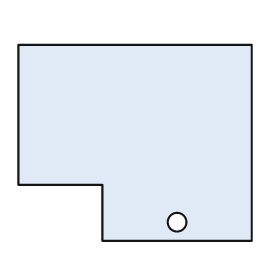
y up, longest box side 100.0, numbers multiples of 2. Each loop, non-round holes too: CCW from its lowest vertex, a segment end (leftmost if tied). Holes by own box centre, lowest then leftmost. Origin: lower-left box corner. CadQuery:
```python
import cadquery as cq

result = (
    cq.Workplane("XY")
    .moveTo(36.0, 0.0)
    .lineTo(100.0, 0.0)
    .lineTo(100.0, 84.0)
    .lineTo(0.0, 84.0)
    .lineTo(0.0, 24.0)
    .lineTo(36.0, 24.0)
    .close()
    .moveTo(68.0, 8.0)
    .circle(4.0)
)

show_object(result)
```